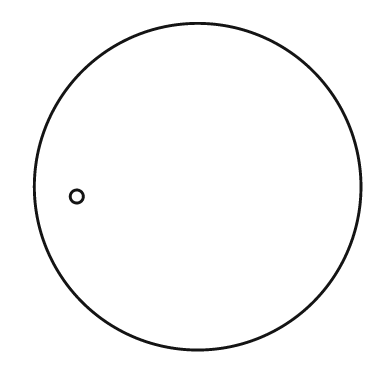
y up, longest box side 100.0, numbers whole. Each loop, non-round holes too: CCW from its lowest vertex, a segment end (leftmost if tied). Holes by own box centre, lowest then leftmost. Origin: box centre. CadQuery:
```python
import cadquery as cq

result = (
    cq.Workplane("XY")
    .moveTo(0.0, 0.0)
    .circle(50.0)
    .moveTo(-37.0, -3.0)
    .circle(2.0)
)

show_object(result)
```